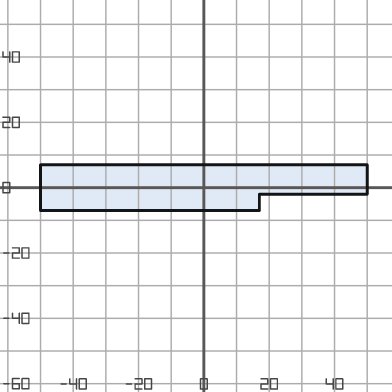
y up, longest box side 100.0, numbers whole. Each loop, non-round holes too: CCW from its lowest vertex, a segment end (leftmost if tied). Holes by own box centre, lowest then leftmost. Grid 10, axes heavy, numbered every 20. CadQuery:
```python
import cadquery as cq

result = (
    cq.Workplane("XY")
    .moveTo(-50.0, -7.0)
    .lineTo(17.0, -7.0)
    .lineTo(17.0, -2.0)
    .lineTo(50.0, -2.0)
    .lineTo(50.0, 7.0)
    .lineTo(-50.0, 7.0)
    .close()
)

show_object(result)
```